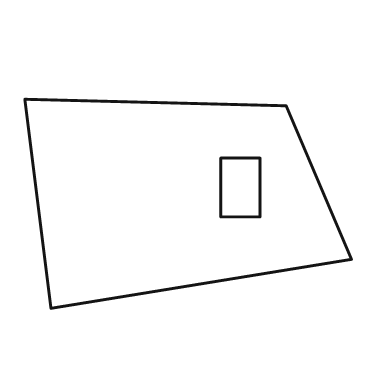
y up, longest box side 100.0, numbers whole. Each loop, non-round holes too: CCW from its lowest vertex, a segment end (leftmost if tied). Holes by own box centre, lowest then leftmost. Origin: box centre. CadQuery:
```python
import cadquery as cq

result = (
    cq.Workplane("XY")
    .moveTo(-42.0, -32.0)
    .lineTo(50.0, -17.0)
    .lineTo(30.0, 30.0)
    .lineTo(-50.0, 32.0)
    .close()
    .moveTo(10.0, -4.0)
    .lineTo(22.0, -4.0)
    .lineTo(22.0, 14.0)
    .lineTo(10.0, 14.0)
    .close()
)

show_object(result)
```